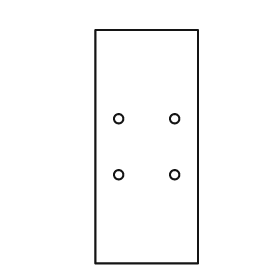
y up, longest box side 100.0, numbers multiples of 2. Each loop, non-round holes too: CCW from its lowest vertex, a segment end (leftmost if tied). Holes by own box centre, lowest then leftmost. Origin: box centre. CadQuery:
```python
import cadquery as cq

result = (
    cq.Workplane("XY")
    .moveTo(-22.0, -50.0)
    .lineTo(22.0, -50.0)
    .lineTo(22.0, 50.0)
    .lineTo(-22.0, 50.0)
    .close()
    .moveTo(-12.0, -12.0)
    .circle(2.0)
    .moveTo(12.0, -12.0)
    .circle(2.0)
    .moveTo(-12.0, 12.0)
    .circle(2.0)
    .moveTo(12.0, 12.0)
    .circle(2.0)
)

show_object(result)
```